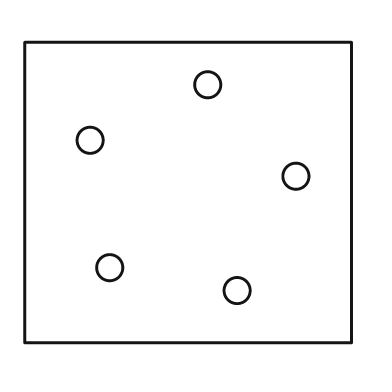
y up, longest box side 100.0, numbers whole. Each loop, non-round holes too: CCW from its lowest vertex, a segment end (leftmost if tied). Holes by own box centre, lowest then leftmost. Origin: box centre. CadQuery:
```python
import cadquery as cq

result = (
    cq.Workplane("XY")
    .moveTo(-50.0, -46.0)
    .lineTo(50.0, -46.0)
    .lineTo(50.0, 46.0)
    .lineTo(-50.0, 46.0)
    .close()
    .moveTo(15.0, -30.0)
    .circle(4.0)
    .moveTo(-24.0, -23.0)
    .circle(4.0)
    .moveTo(33.0, 5.0)
    .circle(4.0)
    .moveTo(-30.0, 16.0)
    .circle(4.0)
    .moveTo(6.0, 33.0)
    .circle(4.0)
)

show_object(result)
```